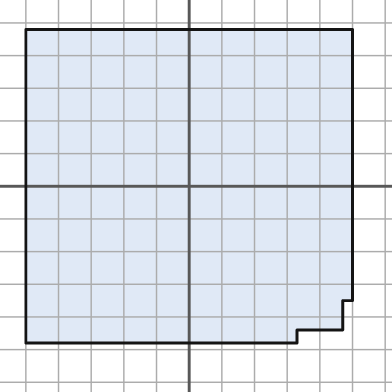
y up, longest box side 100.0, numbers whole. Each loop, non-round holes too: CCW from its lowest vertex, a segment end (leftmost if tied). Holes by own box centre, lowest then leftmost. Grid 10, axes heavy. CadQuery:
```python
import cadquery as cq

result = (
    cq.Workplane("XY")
    .moveTo(-50.0, -48.0)
    .lineTo(33.0, -48.0)
    .lineTo(33.0, -44.0)
    .lineTo(47.0, -44.0)
    .lineTo(47.0, -35.0)
    .lineTo(50.0, -35.0)
    .lineTo(50.0, 48.0)
    .lineTo(-50.0, 48.0)
    .close()
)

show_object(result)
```